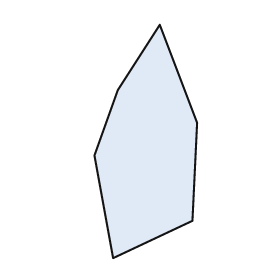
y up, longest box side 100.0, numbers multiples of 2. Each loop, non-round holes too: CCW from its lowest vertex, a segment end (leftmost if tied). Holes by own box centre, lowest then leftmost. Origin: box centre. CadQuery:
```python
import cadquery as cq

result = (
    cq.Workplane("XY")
    .moveTo(-14.0, -50.0)
    .lineTo(20.0, -34.0)
    .lineTo(22.0, 8.0)
    .lineTo(6.0, 50.0)
    .lineTo(-12.0, 22.0)
    .lineTo(-22.0, -6.0)
    .close()
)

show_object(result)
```